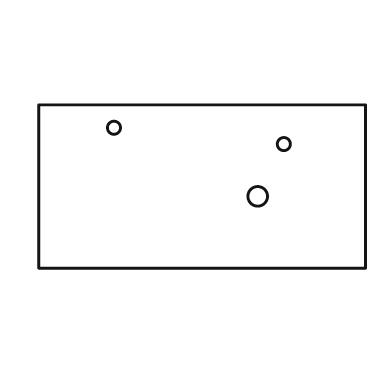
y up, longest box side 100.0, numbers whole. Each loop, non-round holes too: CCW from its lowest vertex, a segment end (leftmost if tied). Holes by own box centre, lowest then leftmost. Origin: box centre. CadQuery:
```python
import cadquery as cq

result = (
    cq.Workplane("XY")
    .moveTo(-50.0, -25.0)
    .lineTo(50.0, -25.0)
    .lineTo(50.0, 25.0)
    .lineTo(-50.0, 25.0)
    .close()
    .moveTo(17.0, -3.0)
    .circle(3.0)
    .moveTo(25.0, 13.0)
    .circle(2.0)
    .moveTo(-27.0, 18.0)
    .circle(2.0)
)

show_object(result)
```